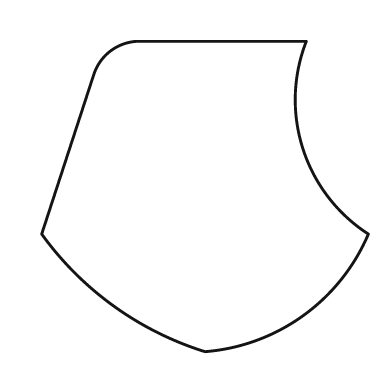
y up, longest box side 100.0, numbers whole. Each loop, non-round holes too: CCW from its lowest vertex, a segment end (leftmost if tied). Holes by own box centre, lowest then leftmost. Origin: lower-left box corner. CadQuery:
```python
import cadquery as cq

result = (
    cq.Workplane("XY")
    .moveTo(50.0, 0.0)
    .threePointArc((80.0, 11.0), (100.0, 36.0))
    .threePointArc((80.0, 62.0), (81.0, 95.0))
    .lineTo(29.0, 95.0)
    .threePointArc((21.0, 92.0), (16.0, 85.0))
    .lineTo(0.0, 36.0)
    .threePointArc((22.0, 14.0), (50.0, 0.0))
    .close()
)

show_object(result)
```